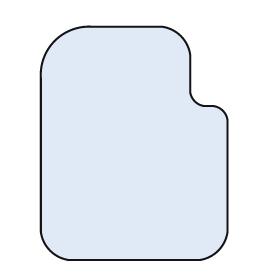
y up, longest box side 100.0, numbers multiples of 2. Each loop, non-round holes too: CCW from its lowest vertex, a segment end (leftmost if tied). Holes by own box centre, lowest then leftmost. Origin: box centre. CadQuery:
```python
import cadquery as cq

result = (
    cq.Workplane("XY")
    .moveTo(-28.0, -50.0)
    .lineTo(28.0, -50.0)
    .threePointArc((36.0, -46.0), (40.0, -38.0))
    .lineTo(40.0, 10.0)
    .threePointArc((38.0, 14.0), (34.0, 16.0))
    .lineTo(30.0, 16.0)
    .threePointArc((26.0, 18.0), (24.0, 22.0))
    .lineTo(24.0, 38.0)
    .threePointArc((20.0, 46.0), (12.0, 50.0))
    .lineTo(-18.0, 50.0)
    .threePointArc((-34.0, 44.0), (-40.0, 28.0))
    .lineTo(-40.0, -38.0)
    .threePointArc((-36.0, -46.0), (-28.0, -50.0))
    .close()
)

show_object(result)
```